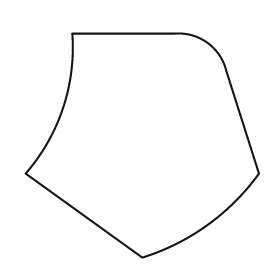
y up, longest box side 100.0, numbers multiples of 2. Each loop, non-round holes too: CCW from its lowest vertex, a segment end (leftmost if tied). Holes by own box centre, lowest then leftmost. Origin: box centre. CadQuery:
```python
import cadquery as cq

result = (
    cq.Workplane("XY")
    .moveTo(0.0, -48.0)
    .threePointArc((28.0, -34.0), (50.0, -12.0))
    .lineTo(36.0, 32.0)
    .threePointArc((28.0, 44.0), (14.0, 48.0))
    .lineTo(-30.0, 48.0)
    .threePointArc((-34.0, 16.0), (-50.0, -12.0))
    .close()
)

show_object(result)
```